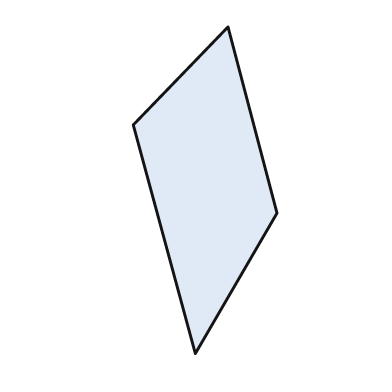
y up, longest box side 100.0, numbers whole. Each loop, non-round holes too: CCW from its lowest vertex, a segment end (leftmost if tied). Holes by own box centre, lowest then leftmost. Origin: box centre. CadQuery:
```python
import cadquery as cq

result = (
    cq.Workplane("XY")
    .moveTo(-3.0, -50.0)
    .lineTo(22.0, -7.0)
    .lineTo(7.0, 50.0)
    .lineTo(-22.0, 20.0)
    .close()
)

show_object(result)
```